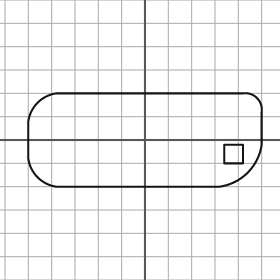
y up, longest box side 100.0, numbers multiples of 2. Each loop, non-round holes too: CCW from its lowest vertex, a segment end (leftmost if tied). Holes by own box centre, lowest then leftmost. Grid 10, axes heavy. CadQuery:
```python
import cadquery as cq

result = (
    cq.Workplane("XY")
    .moveTo(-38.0, -20.0)
    .lineTo(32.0, -20.0)
    .threePointArc((44.0, -14.0), (50.0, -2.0))
    .lineTo(50.0, 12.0)
    .threePointArc((48.0, 18.0), (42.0, 20.0))
    .lineTo(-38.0, 20.0)
    .threePointArc((-46.0, 16.0), (-50.0, 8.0))
    .lineTo(-50.0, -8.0)
    .threePointArc((-46.0, -16.0), (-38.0, -20.0))
    .close()
    .moveTo(34.0, -10.0)
    .lineTo(42.0, -10.0)
    .lineTo(42.0, -2.0)
    .lineTo(34.0, -2.0)
    .close()
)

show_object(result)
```